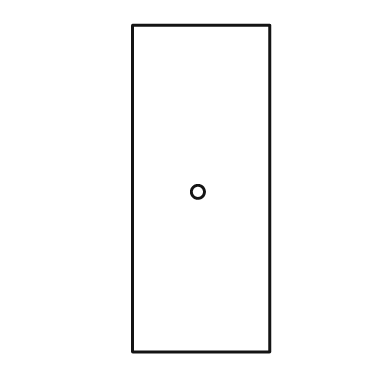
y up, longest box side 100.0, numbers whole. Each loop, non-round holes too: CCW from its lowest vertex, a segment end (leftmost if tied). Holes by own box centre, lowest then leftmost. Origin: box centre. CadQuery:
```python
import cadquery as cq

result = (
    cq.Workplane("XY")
    .moveTo(-21.0, -50.0)
    .lineTo(21.0, -50.0)
    .lineTo(21.0, 50.0)
    .lineTo(-21.0, 50.0)
    .close()
    .moveTo(-1.0, -1.0)
    .circle(2.0)
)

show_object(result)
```